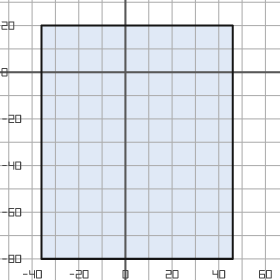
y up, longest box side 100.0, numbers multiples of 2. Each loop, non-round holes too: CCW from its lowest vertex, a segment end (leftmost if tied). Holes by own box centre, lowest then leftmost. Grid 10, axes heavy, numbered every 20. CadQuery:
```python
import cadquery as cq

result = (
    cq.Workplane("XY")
    .moveTo(-36.0, -80.0)
    .lineTo(46.0, -80.0)
    .lineTo(46.0, 20.0)
    .lineTo(-36.0, 20.0)
    .close()
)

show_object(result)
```